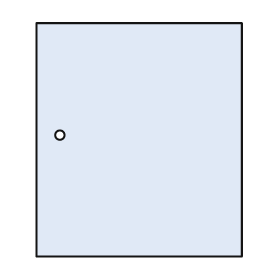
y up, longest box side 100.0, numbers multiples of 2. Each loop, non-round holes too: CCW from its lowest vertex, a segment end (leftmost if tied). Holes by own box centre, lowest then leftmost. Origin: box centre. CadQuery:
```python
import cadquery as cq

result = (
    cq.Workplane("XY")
    .moveTo(-44.0, -50.0)
    .lineTo(44.0, -50.0)
    .lineTo(44.0, 50.0)
    .lineTo(-44.0, 50.0)
    .close()
    .moveTo(-34.0, 2.0)
    .circle(2.0)
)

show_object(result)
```